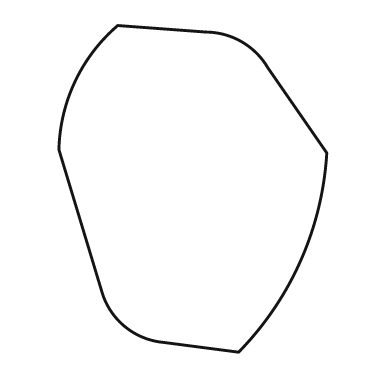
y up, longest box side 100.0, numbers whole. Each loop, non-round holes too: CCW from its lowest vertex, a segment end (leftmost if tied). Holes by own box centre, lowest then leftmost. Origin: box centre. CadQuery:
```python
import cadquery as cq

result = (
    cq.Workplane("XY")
    .moveTo(14.0, -50.0)
    .threePointArc((33.0, -22.0), (41.0, 11.0))
    .lineTo(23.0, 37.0)
    .threePointArc((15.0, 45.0), (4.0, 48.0))
    .lineTo(-23.0, 50.0)
    .threePointArc((-36.0, 33.0), (-41.0, 12.0))
    .lineTo(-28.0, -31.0)
    .threePointArc((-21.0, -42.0), (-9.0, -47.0))
    .close()
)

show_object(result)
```